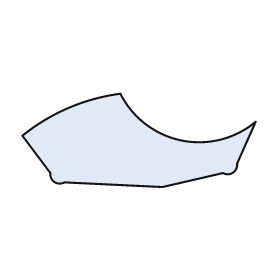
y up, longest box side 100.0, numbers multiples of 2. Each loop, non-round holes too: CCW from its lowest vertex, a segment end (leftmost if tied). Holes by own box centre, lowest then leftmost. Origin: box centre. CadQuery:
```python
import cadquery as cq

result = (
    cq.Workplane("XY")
    .moveTo(10.0, -20.0)
    .lineTo(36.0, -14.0)
    .threePointArc((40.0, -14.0), (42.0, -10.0))
    .lineTo(50.0, 8.0)
    .threePointArc((18.0, 0.0), (-8.0, 20.0))
    .threePointArc((-30.0, 14.0), (-50.0, 2.0))
    .lineTo(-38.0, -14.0)
    .threePointArc((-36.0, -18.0), (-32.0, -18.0))
    .close()
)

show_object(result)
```